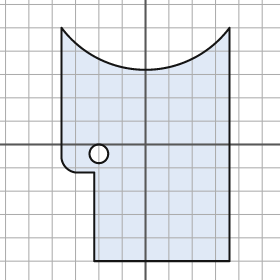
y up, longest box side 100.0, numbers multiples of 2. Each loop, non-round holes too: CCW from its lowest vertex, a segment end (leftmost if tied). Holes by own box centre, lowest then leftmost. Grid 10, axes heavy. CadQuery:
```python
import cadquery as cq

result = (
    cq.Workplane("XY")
    .moveTo(-22.0, -50.0)
    .lineTo(36.0, -50.0)
    .lineTo(36.0, 50.0)
    .threePointArc((0.0, 32.0), (-36.0, 50.0))
    .lineTo(-36.0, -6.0)
    .threePointArc((-34.0, -10.0), (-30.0, -12.0))
    .lineTo(-22.0, -12.0)
    .close()
    .moveTo(-20.0, -4.0)
    .circle(4.0)
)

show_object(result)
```